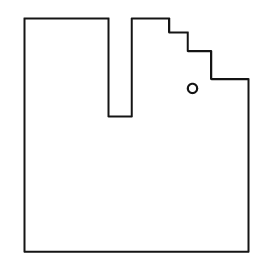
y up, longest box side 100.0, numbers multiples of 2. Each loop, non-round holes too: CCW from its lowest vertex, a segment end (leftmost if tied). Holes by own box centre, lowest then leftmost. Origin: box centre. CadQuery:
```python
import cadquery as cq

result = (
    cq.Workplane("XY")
    .moveTo(-48.0, -50.0)
    .lineTo(48.0, -50.0)
    .lineTo(48.0, 24.0)
    .lineTo(32.0, 24.0)
    .lineTo(32.0, 36.0)
    .lineTo(22.0, 36.0)
    .lineTo(22.0, 44.0)
    .lineTo(14.0, 44.0)
    .lineTo(14.0, 50.0)
    .lineTo(-2.0, 50.0)
    .lineTo(-2.0, 8.0)
    .lineTo(-12.0, 8.0)
    .lineTo(-12.0, 50.0)
    .lineTo(-48.0, 50.0)
    .close()
    .moveTo(24.0, 20.0)
    .circle(2.0)
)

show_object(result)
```